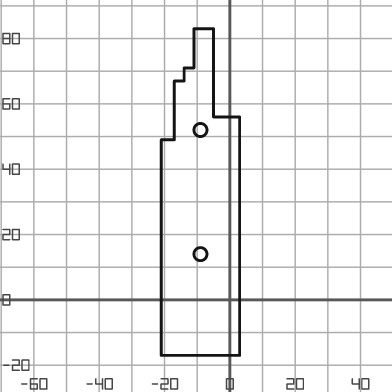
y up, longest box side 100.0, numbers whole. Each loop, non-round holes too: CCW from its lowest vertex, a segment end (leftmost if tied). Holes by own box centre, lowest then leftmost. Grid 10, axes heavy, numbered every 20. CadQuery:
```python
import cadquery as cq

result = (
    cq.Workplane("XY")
    .moveTo(-21.0, -17.0)
    .lineTo(3.0, -17.0)
    .lineTo(3.0, 56.0)
    .lineTo(-5.0, 56.0)
    .lineTo(-5.0, 83.0)
    .lineTo(-11.0, 83.0)
    .lineTo(-11.0, 71.0)
    .lineTo(-14.0, 71.0)
    .lineTo(-14.0, 67.0)
    .lineTo(-17.0, 67.0)
    .lineTo(-17.0, 49.0)
    .lineTo(-21.0, 49.0)
    .close()
    .moveTo(-9.0, 14.0)
    .circle(2.0)
    .moveTo(-9.0, 52.0)
    .circle(2.0)
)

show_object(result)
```